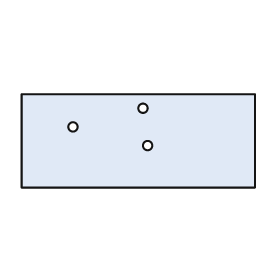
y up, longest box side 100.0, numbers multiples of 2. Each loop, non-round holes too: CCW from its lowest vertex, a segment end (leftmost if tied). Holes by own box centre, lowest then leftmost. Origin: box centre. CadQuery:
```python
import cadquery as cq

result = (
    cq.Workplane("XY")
    .moveTo(-50.0, -20.0)
    .lineTo(50.0, -20.0)
    .lineTo(50.0, 20.0)
    .lineTo(-50.0, 20.0)
    .close()
    .moveTo(4.0, -2.0)
    .circle(2.0)
    .moveTo(-28.0, 6.0)
    .circle(2.0)
    .moveTo(2.0, 14.0)
    .circle(2.0)
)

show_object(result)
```